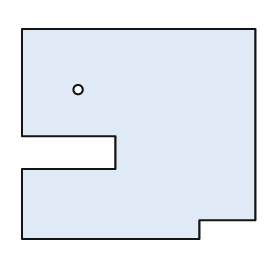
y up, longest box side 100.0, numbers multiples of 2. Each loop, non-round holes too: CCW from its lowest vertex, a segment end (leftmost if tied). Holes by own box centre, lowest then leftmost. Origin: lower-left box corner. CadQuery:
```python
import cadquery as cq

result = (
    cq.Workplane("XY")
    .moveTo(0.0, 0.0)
    .lineTo(76.0, 0.0)
    .lineTo(76.0, 8.0)
    .lineTo(100.0, 8.0)
    .lineTo(100.0, 90.0)
    .lineTo(0.0, 90.0)
    .lineTo(0.0, 44.0)
    .lineTo(40.0, 44.0)
    .lineTo(40.0, 30.0)
    .lineTo(0.0, 30.0)
    .close()
    .moveTo(24.0, 64.0)
    .circle(2.0)
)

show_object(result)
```